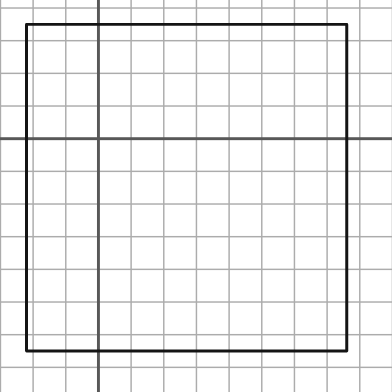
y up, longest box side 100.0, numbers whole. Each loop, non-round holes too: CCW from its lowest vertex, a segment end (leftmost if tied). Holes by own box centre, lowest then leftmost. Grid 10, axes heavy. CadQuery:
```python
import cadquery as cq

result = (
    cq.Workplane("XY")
    .moveTo(-22.0, -65.0)
    .lineTo(76.0, -65.0)
    .lineTo(76.0, 35.0)
    .lineTo(-22.0, 35.0)
    .close()
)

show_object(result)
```